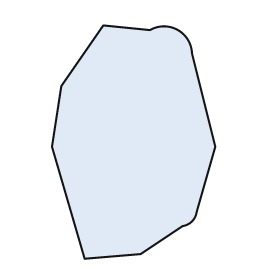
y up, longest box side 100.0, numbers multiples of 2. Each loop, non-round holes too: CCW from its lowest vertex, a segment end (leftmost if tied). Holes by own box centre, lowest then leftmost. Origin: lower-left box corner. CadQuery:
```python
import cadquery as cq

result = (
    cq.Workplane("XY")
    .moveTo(14.0, 0.0)
    .lineTo(38.0, 2.0)
    .lineTo(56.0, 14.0)
    .threePointArc((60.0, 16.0), (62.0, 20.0))
    .lineTo(70.0, 48.0)
    .lineTo(60.0, 88.0)
    .threePointArc((54.0, 98.0), (42.0, 98.0))
    .lineTo(22.0, 100.0)
    .lineTo(4.0, 74.0)
    .lineTo(0.0, 48.0)
    .close()
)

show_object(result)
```